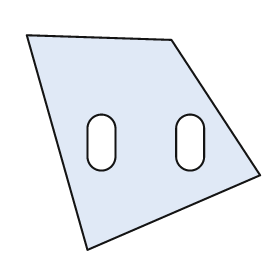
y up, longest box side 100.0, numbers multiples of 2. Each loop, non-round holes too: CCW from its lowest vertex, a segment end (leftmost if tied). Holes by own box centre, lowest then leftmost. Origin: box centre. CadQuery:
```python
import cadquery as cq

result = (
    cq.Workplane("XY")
    .moveTo(-24.0, -46.0)
    .lineTo(50.0, -14.0)
    .lineTo(12.0, 44.0)
    .lineTo(-50.0, 46.0)
    .close()
    .moveTo(-24.0, -6.0)
    .threePointArc((-18.0, -12.0), (-12.0, -6.0))
    .lineTo(-12.0, 6.0)
    .threePointArc((-18.0, 12.0), (-24.0, 6.0))
    .close()
    .moveTo(14.0, -6.0)
    .threePointArc((20.0, -12.0), (26.0, -6.0))
    .lineTo(26.0, 6.0)
    .threePointArc((20.0, 12.0), (14.0, 6.0))
    .close()
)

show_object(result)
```